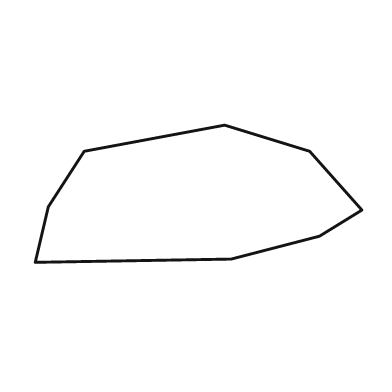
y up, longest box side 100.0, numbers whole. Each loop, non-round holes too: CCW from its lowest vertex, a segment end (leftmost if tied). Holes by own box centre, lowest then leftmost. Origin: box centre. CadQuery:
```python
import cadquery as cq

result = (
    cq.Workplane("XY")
    .moveTo(-50.0, -21.0)
    .lineTo(10.0, -20.0)
    .lineTo(37.0, -13.0)
    .lineTo(50.0, -5.0)
    .lineTo(34.0, 13.0)
    .lineTo(8.0, 21.0)
    .lineTo(-35.0, 13.0)
    .lineTo(-46.0, -4.0)
    .close()
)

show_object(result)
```